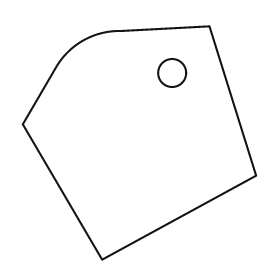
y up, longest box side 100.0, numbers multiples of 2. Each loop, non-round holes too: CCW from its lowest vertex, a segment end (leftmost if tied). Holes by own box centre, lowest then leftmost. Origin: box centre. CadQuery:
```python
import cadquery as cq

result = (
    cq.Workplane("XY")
    .moveTo(-16.0, -50.0)
    .lineTo(50.0, -14.0)
    .lineTo(30.0, 50.0)
    .lineTo(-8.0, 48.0)
    .threePointArc((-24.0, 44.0), (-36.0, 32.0))
    .lineTo(-50.0, 8.0)
    .close()
    .moveTo(14.0, 30.0)
    .circle(6.0)
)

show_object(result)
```